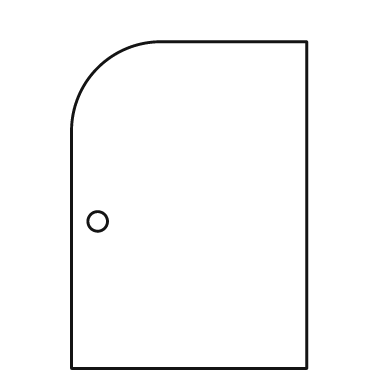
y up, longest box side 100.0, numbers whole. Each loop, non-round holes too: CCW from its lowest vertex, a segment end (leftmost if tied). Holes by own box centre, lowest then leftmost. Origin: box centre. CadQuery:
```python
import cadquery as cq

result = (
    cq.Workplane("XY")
    .moveTo(-36.0, -50.0)
    .lineTo(36.0, -50.0)
    .lineTo(36.0, 50.0)
    .lineTo(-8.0, 50.0)
    .threePointArc((-28.0, 42.0), (-36.0, 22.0))
    .close()
    .moveTo(-28.0, -5.0)
    .circle(3.0)
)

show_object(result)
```